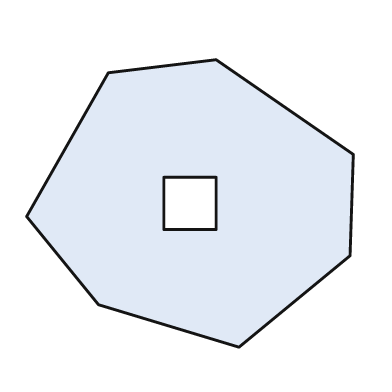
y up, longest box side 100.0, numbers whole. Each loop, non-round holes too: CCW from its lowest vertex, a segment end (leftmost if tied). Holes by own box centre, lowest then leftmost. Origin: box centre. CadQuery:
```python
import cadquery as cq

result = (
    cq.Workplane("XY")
    .moveTo(15.0, -44.0)
    .lineTo(49.0, -16.0)
    .lineTo(50.0, 15.0)
    .lineTo(8.0, 44.0)
    .lineTo(-25.0, 40.0)
    .lineTo(-50.0, -4.0)
    .lineTo(-28.0, -31.0)
    .close()
    .moveTo(-8.0, -8.0)
    .lineTo(8.0, -8.0)
    .lineTo(8.0, 8.0)
    .lineTo(-8.0, 8.0)
    .close()
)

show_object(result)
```